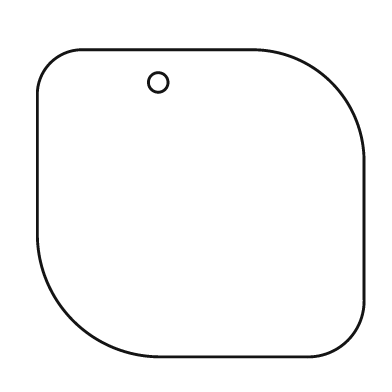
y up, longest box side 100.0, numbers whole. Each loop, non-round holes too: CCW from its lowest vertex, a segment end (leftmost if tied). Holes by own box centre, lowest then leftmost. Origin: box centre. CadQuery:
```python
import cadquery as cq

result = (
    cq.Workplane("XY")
    .moveTo(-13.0, -47.0)
    .lineTo(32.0, -47.0)
    .threePointArc((45.0, -42.0), (50.0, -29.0))
    .lineTo(50.0, 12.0)
    .threePointArc((40.0, 37.0), (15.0, 47.0))
    .lineTo(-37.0, 47.0)
    .threePointArc((-46.0, 43.0), (-50.0, 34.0))
    .lineTo(-50.0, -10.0)
    .threePointArc((-39.0, -36.0), (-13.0, -47.0))
    .close()
    .moveTo(-13.0, 37.0)
    .circle(3.0)
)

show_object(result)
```